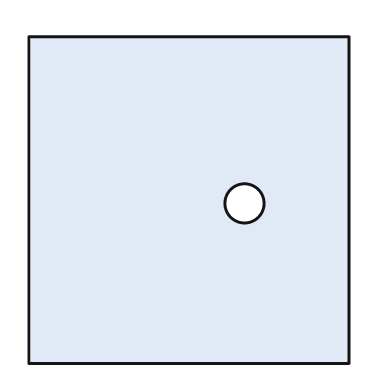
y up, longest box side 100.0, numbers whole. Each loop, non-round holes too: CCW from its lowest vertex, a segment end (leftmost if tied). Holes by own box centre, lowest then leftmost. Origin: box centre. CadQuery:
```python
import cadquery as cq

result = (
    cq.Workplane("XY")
    .moveTo(-49.0, -50.0)
    .lineTo(49.0, -50.0)
    .lineTo(49.0, 50.0)
    .lineTo(-49.0, 50.0)
    .close()
    .moveTo(17.0, -1.0)
    .circle(6.0)
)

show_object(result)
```